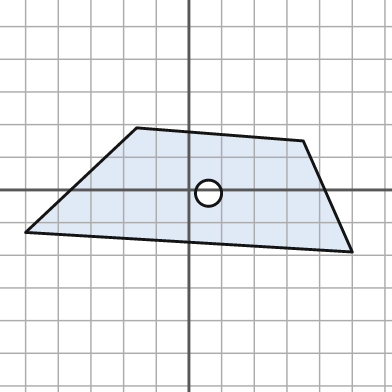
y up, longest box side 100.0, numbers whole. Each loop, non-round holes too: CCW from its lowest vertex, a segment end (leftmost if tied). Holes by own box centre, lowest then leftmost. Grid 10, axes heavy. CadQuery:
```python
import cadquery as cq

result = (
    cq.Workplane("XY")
    .moveTo(50.0, -19.0)
    .lineTo(35.0, 15.0)
    .lineTo(-16.0, 19.0)
    .lineTo(-50.0, -13.0)
    .close()
    .moveTo(6.0, -1.0)
    .circle(4.0)
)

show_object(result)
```